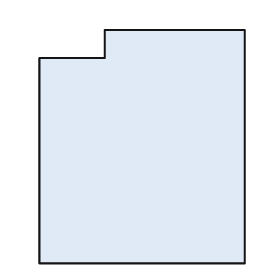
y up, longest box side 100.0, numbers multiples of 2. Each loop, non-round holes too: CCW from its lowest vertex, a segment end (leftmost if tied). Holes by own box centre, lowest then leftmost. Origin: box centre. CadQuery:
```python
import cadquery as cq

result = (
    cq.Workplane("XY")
    .moveTo(-44.0, -50.0)
    .lineTo(44.0, -50.0)
    .lineTo(44.0, 50.0)
    .lineTo(-16.0, 50.0)
    .lineTo(-16.0, 38.0)
    .lineTo(-44.0, 38.0)
    .close()
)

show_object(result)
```